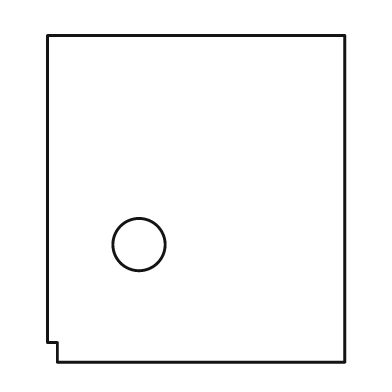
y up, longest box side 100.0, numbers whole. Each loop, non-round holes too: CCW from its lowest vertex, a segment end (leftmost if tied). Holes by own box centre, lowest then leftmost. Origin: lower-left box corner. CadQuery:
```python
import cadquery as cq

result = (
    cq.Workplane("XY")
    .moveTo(3.0, 0.0)
    .lineTo(91.0, 0.0)
    .lineTo(91.0, 100.0)
    .lineTo(0.0, 100.0)
    .lineTo(0.0, 6.0)
    .lineTo(3.0, 6.0)
    .close()
    .moveTo(28.0, 36.0)
    .circle(8.0)
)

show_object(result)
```